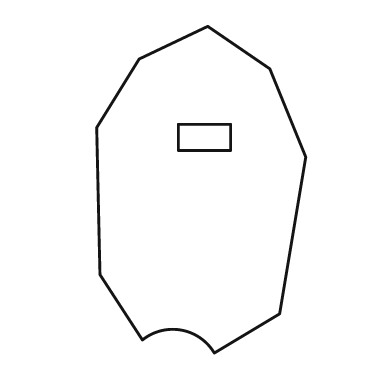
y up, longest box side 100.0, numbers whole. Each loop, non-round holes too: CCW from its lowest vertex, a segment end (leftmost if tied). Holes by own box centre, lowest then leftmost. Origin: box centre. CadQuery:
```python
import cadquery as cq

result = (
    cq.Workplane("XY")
    .moveTo(4.0, -50.0)
    .lineTo(24.0, -38.0)
    .lineTo(32.0, 10.0)
    .lineTo(21.0, 37.0)
    .lineTo(2.0, 50.0)
    .lineTo(-19.0, 40.0)
    .lineTo(-32.0, 19.0)
    .lineTo(-31.0, -26.0)
    .lineTo(-18.0, -46.0)
    .threePointArc((-6.0, -43.0), (4.0, -50.0))
    .close()
    .moveTo(-7.0, 12.0)
    .lineTo(9.0, 12.0)
    .lineTo(9.0, 20.0)
    .lineTo(-7.0, 20.0)
    .close()
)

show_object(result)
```